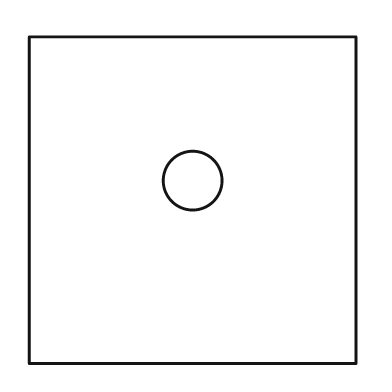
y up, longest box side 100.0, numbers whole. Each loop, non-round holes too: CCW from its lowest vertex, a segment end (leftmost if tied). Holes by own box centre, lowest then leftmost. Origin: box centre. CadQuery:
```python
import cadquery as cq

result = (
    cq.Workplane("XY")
    .moveTo(-50.0, -50.0)
    .lineTo(50.0, -50.0)
    .lineTo(50.0, 50.0)
    .lineTo(-50.0, 50.0)
    .close()
    .moveTo(0.0, 6.0)
    .circle(9.0)
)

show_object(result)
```